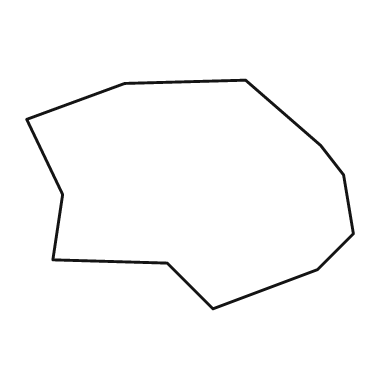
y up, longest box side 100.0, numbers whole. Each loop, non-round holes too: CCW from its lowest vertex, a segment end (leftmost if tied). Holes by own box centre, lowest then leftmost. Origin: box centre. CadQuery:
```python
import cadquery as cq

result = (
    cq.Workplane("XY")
    .moveTo(7.0, -35.0)
    .lineTo(39.0, -23.0)
    .lineTo(50.0, -12.0)
    .lineTo(47.0, 6.0)
    .lineTo(40.0, 15.0)
    .lineTo(17.0, 35.0)
    .lineTo(-20.0, 34.0)
    .lineTo(-50.0, 23.0)
    .lineTo(-39.0, 0.0)
    .lineTo(-42.0, -20.0)
    .lineTo(-7.0, -21.0)
    .close()
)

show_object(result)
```